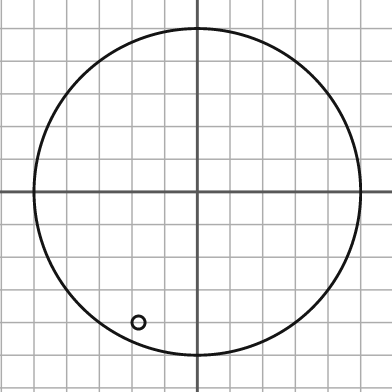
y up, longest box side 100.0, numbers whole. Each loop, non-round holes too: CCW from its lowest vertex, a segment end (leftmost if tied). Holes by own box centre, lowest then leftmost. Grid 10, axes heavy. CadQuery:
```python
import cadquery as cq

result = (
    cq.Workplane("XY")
    .moveTo(0.0, 0.0)
    .circle(50.0)
    .moveTo(-18.0, -40.0)
    .circle(2.0)
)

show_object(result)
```